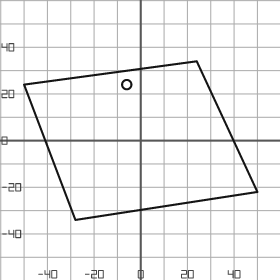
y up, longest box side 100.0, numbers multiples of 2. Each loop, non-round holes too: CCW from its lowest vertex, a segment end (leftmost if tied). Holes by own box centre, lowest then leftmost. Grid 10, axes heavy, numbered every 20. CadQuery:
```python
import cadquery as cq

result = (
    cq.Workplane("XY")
    .moveTo(-28.0, -34.0)
    .lineTo(50.0, -22.0)
    .lineTo(24.0, 34.0)
    .lineTo(-50.0, 24.0)
    .close()
    .moveTo(-6.0, 24.0)
    .circle(2.0)
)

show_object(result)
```